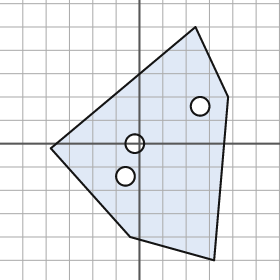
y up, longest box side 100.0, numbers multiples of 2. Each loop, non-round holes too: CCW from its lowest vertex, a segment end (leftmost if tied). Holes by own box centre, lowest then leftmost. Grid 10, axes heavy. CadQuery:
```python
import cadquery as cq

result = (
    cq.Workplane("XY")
    .moveTo(32.0, -50.0)
    .lineTo(38.0, 20.0)
    .lineTo(24.0, 50.0)
    .lineTo(-38.0, -2.0)
    .lineTo(-4.0, -40.0)
    .close()
    .moveTo(-6.0, -14.0)
    .circle(4.0)
    .moveTo(-2.0, 0.0)
    .circle(4.0)
    .moveTo(26.0, 16.0)
    .circle(4.0)
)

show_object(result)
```